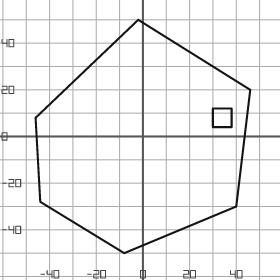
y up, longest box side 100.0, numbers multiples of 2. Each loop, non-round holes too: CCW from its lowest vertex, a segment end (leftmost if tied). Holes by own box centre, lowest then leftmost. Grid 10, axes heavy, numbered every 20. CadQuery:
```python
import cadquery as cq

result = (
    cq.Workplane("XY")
    .moveTo(-8.0, -50.0)
    .lineTo(40.0, -30.0)
    .lineTo(46.0, 20.0)
    .lineTo(-2.0, 50.0)
    .lineTo(-46.0, 8.0)
    .lineTo(-44.0, -28.0)
    .close()
    .moveTo(30.0, 4.0)
    .lineTo(38.0, 4.0)
    .lineTo(38.0, 12.0)
    .lineTo(30.0, 12.0)
    .close()
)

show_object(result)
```